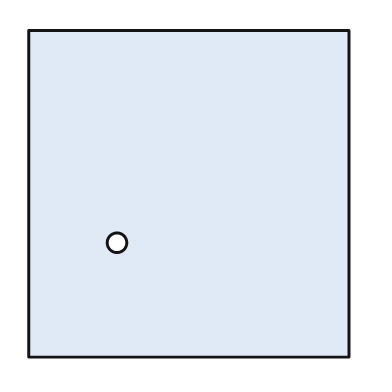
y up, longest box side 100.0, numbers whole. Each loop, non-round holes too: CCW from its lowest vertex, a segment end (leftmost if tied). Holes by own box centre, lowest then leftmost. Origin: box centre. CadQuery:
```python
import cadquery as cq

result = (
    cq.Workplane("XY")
    .moveTo(-49.0, -50.0)
    .lineTo(49.0, -50.0)
    .lineTo(49.0, 50.0)
    .lineTo(-49.0, 50.0)
    .close()
    .moveTo(-22.0, -15.0)
    .circle(3.0)
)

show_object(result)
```